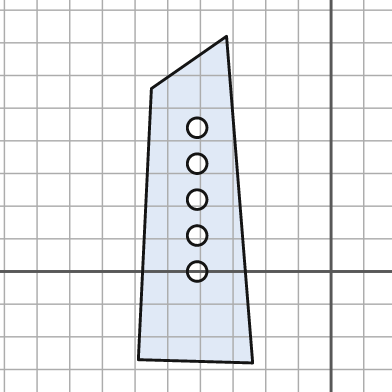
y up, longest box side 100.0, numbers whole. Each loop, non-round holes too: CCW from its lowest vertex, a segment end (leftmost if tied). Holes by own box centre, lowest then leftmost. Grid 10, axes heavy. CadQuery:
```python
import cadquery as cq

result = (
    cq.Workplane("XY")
    .moveTo(-24.0, -28.0)
    .lineTo(-32.0, 72.0)
    .lineTo(-55.0, 56.0)
    .lineTo(-59.0, -27.0)
    .close()
    .moveTo(-41.0, 0.0)
    .circle(3.0)
    .moveTo(-41.0, 11.0)
    .circle(3.0)
    .moveTo(-41.0, 22.0)
    .circle(3.0)
    .moveTo(-41.0, 33.0)
    .circle(3.0)
    .moveTo(-41.0, 44.0)
    .circle(3.0)
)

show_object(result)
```